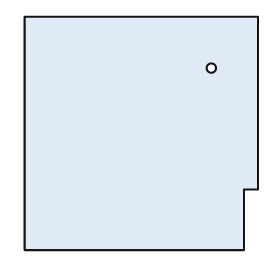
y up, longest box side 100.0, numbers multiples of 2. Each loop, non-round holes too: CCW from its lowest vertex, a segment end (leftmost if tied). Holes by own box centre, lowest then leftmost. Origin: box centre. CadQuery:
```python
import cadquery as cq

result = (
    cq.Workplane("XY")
    .moveTo(-50.0, -50.0)
    .lineTo(44.0, -50.0)
    .lineTo(44.0, -24.0)
    .lineTo(50.0, -24.0)
    .lineTo(50.0, 50.0)
    .lineTo(-50.0, 50.0)
    .close()
    .moveTo(30.0, 28.0)
    .circle(2.0)
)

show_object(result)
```